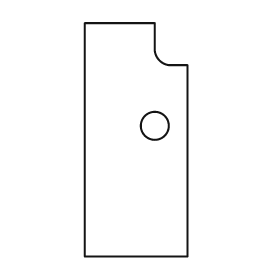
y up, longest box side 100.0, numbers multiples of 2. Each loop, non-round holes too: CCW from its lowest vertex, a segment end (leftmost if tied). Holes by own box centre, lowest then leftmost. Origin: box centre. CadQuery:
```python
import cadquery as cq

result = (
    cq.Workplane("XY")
    .moveTo(-22.0, -50.0)
    .lineTo(22.0, -50.0)
    .lineTo(22.0, 32.0)
    .lineTo(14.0, 32.0)
    .threePointArc((10.0, 34.0), (8.0, 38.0))
    .lineTo(8.0, 50.0)
    .lineTo(-22.0, 50.0)
    .close()
    .moveTo(8.0, 6.0)
    .circle(6.0)
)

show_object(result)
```